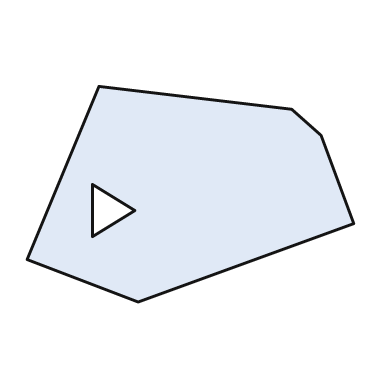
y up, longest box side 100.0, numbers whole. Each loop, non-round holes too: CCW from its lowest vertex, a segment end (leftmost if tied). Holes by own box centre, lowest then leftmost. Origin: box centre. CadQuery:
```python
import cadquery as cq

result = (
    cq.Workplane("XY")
    .moveTo(-16.0, -33.0)
    .lineTo(50.0, -9.0)
    .lineTo(40.0, 18.0)
    .lineTo(31.0, 26.0)
    .lineTo(-28.0, 33.0)
    .lineTo(-50.0, -20.0)
    .close()
    .moveTo(-30.0, -13.0)
    .lineTo(-17.0, -5.0)
    .lineTo(-30.0, 3.0)
    .close()
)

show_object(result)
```